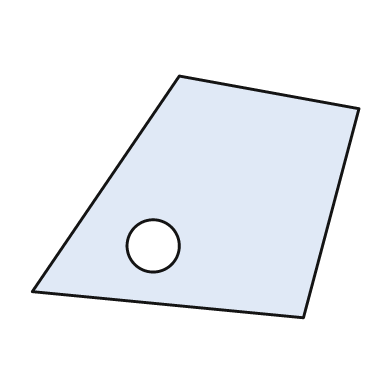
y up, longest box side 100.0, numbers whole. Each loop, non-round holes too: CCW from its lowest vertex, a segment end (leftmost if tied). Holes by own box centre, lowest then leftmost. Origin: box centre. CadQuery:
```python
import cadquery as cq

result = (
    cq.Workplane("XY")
    .moveTo(33.0, -37.0)
    .lineTo(50.0, 27.0)
    .lineTo(-5.0, 37.0)
    .lineTo(-50.0, -29.0)
    .close()
    .moveTo(-13.0, -15.0)
    .circle(8.0)
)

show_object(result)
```